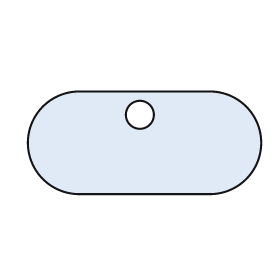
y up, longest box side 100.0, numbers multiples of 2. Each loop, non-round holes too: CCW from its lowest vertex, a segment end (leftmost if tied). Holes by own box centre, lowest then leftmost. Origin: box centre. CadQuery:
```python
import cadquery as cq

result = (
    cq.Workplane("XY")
    .moveTo(-28.0, -22.0)
    .lineTo(28.0, -22.0)
    .threePointArc((50.0, 0.0), (28.0, 22.0))
    .lineTo(-28.0, 22.0)
    .threePointArc((-50.0, 0.0), (-28.0, -22.0))
    .close()
    .moveTo(-2.0, 12.0)
    .circle(6.0)
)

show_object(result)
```